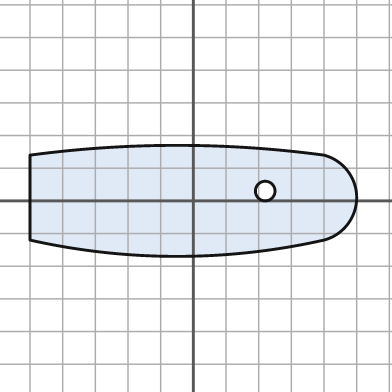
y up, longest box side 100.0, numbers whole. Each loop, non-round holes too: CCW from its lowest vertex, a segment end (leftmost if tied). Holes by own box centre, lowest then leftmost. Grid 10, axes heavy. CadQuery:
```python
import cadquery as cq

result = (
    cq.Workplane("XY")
    .moveTo(-50.0, -12.0)
    .threePointArc((-5.0, -17.0), (40.0, -12.0))
    .threePointArc((50.0, 1.0), (40.0, 14.0))
    .threePointArc((-5.0, 17.0), (-50.0, 14.0))
    .close()
    .moveTo(22.0, 3.0)
    .circle(3.0)
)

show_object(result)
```